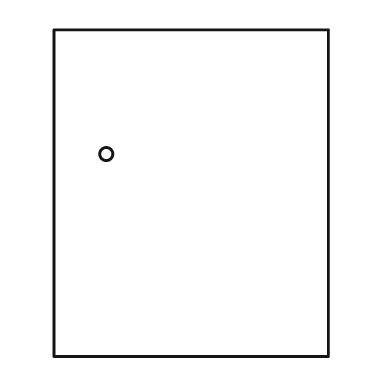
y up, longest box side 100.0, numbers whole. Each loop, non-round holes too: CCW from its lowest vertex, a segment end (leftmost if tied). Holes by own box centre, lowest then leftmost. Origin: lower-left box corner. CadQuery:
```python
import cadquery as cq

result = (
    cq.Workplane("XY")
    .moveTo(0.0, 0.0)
    .lineTo(84.0, 0.0)
    .lineTo(84.0, 100.0)
    .lineTo(0.0, 100.0)
    .close()
    .moveTo(16.0, 62.0)
    .circle(2.0)
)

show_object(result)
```